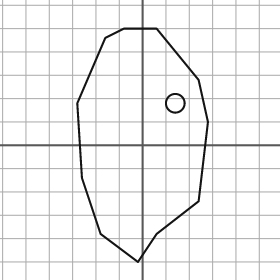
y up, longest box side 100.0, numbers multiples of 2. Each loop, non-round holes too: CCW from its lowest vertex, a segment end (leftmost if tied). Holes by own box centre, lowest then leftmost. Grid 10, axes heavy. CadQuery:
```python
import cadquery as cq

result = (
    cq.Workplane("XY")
    .moveTo(-2.0, -50.0)
    .lineTo(6.0, -38.0)
    .lineTo(24.0, -24.0)
    .lineTo(28.0, 10.0)
    .lineTo(24.0, 28.0)
    .lineTo(6.0, 50.0)
    .lineTo(-8.0, 50.0)
    .lineTo(-16.0, 46.0)
    .lineTo(-28.0, 18.0)
    .lineTo(-26.0, -14.0)
    .lineTo(-18.0, -38.0)
    .close()
    .moveTo(14.0, 18.0)
    .circle(4.0)
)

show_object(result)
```